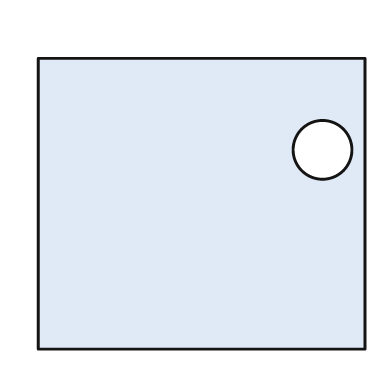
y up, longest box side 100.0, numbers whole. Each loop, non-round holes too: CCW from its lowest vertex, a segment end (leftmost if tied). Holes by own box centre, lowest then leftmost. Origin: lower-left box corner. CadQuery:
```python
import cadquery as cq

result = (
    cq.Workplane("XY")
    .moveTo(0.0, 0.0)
    .lineTo(100.0, 0.0)
    .lineTo(100.0, 89.0)
    .lineTo(0.0, 89.0)
    .close()
    .moveTo(87.0, 61.0)
    .circle(9.0)
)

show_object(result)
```